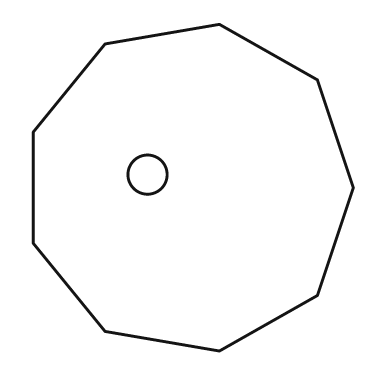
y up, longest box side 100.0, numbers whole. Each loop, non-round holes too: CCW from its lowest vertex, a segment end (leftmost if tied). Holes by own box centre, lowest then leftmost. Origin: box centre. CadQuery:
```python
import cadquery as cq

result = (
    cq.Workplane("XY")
    .moveTo(8.0, -50.0)
    .lineTo(38.0, -33.0)
    .lineTo(49.0, 0.0)
    .lineTo(38.0, 33.0)
    .lineTo(8.0, 50.0)
    .lineTo(-27.0, 44.0)
    .lineTo(-49.0, 17.0)
    .lineTo(-49.0, -17.0)
    .lineTo(-27.0, -44.0)
    .close()
    .moveTo(-14.0, 4.0)
    .circle(6.0)
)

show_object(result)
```